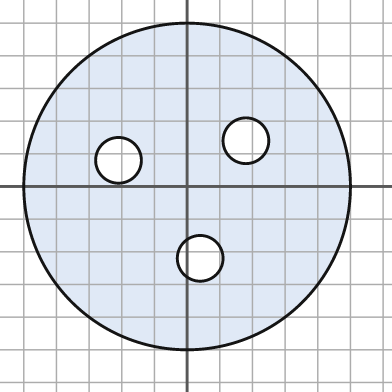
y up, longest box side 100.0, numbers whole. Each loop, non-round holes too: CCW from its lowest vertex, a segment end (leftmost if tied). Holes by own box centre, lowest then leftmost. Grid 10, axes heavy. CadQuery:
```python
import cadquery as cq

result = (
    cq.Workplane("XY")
    .moveTo(0.0, 0.0)
    .circle(50.0)
    .moveTo(4.0, -22.0)
    .circle(7.0)
    .moveTo(-21.0, 8.0)
    .circle(7.0)
    .moveTo(18.0, 14.0)
    .circle(7.0)
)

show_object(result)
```